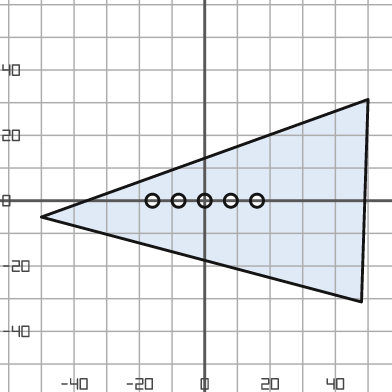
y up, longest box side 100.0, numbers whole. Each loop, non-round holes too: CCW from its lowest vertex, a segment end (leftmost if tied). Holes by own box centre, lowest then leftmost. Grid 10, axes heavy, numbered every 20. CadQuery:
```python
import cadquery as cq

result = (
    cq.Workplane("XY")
    .moveTo(48.0, -31.0)
    .lineTo(50.0, 31.0)
    .lineTo(-50.0, -5.0)
    .close()
    .moveTo(-16.0, 0.0)
    .circle(2.0)
    .moveTo(-8.0, 0.0)
    .circle(2.0)
    .moveTo(0.0, 0.0)
    .circle(2.0)
    .moveTo(8.0, 0.0)
    .circle(2.0)
    .moveTo(16.0, 0.0)
    .circle(2.0)
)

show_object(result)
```